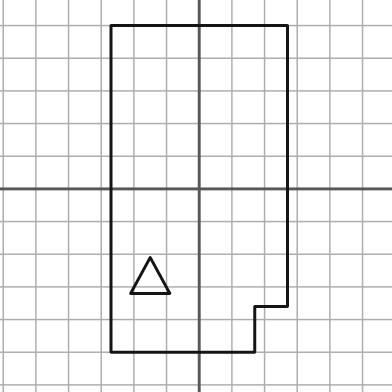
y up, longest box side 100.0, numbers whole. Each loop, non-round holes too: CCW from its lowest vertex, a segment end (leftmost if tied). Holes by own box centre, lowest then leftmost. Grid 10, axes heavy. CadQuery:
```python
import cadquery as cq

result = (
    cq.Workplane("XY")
    .moveTo(-27.0, -50.0)
    .lineTo(17.0, -50.0)
    .lineTo(17.0, -36.0)
    .lineTo(27.0, -36.0)
    .lineTo(27.0, 50.0)
    .lineTo(-27.0, 50.0)
    .close()
    .moveTo(-21.0, -32.0)
    .lineTo(-9.0, -32.0)
    .lineTo(-15.0, -21.0)
    .close()
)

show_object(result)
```